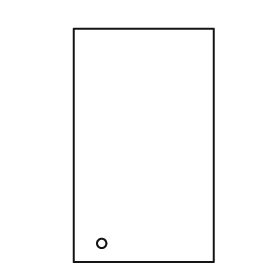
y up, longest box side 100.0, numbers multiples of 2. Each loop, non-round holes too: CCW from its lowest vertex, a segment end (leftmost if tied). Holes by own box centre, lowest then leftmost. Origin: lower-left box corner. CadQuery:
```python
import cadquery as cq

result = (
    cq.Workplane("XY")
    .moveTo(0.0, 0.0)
    .lineTo(60.0, 0.0)
    .lineTo(60.0, 100.0)
    .lineTo(0.0, 100.0)
    .close()
    .moveTo(12.0, 8.0)
    .circle(2.0)
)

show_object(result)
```